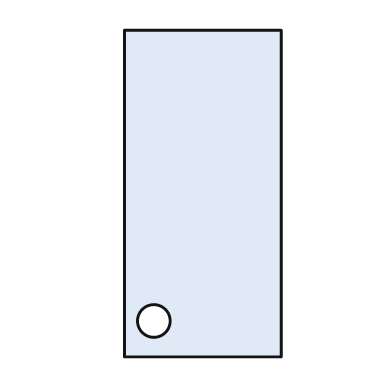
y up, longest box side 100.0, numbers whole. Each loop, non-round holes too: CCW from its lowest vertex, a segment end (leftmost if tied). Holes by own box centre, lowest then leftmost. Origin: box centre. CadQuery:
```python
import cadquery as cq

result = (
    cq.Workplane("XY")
    .moveTo(-24.0, -50.0)
    .lineTo(24.0, -50.0)
    .lineTo(24.0, 50.0)
    .lineTo(-24.0, 50.0)
    .close()
    .moveTo(-15.0, -39.0)
    .circle(5.0)
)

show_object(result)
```